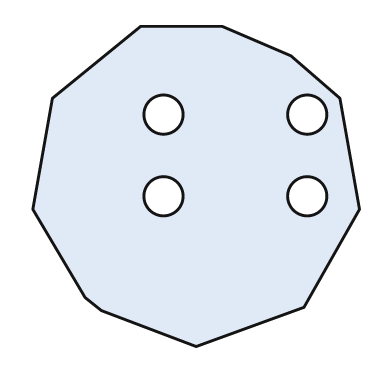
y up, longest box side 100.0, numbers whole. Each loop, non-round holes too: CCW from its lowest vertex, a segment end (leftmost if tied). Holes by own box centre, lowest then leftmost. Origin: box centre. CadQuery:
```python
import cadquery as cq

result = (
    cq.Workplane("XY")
    .moveTo(0.0, -49.0)
    .lineTo(33.0, -37.0)
    .lineTo(50.0, -7.0)
    .lineTo(44.0, 27.0)
    .lineTo(29.0, 40.0)
    .lineTo(8.0, 49.0)
    .lineTo(-17.0, 49.0)
    .lineTo(-44.0, 27.0)
    .lineTo(-50.0, -7.0)
    .lineTo(-34.0, -34.0)
    .lineTo(-29.0, -38.0)
    .close()
    .moveTo(-10.0, -3.0)
    .circle(6.0)
    .moveTo(34.0, -3.0)
    .circle(6.0)
    .moveTo(-10.0, 22.0)
    .circle(6.0)
    .moveTo(34.0, 22.0)
    .circle(6.0)
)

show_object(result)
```